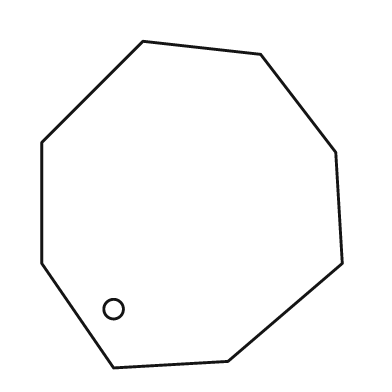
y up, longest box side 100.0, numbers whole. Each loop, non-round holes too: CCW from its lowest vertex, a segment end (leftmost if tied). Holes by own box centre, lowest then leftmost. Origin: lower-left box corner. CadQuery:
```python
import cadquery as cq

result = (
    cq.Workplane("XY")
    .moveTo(22.0, 0.0)
    .lineTo(57.0, 2.0)
    .lineTo(92.0, 32.0)
    .lineTo(90.0, 66.0)
    .lineTo(67.0, 96.0)
    .lineTo(31.0, 100.0)
    .lineTo(0.0, 69.0)
    .lineTo(0.0, 32.0)
    .close()
    .moveTo(22.0, 18.0)
    .circle(3.0)
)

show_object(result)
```